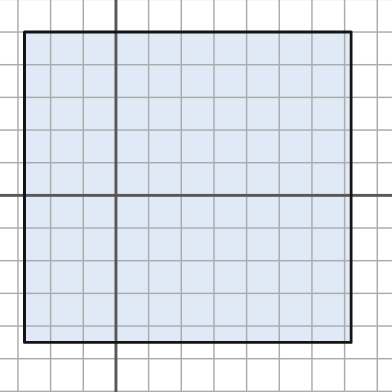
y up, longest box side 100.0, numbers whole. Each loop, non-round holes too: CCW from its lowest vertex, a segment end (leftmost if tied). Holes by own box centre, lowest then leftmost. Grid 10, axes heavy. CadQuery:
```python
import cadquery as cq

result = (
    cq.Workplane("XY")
    .moveTo(-28.0, -45.0)
    .lineTo(72.0, -45.0)
    .lineTo(72.0, 50.0)
    .lineTo(-28.0, 50.0)
    .close()
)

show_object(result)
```